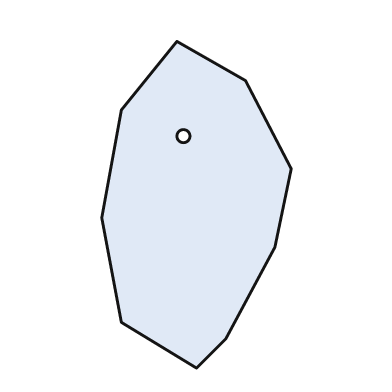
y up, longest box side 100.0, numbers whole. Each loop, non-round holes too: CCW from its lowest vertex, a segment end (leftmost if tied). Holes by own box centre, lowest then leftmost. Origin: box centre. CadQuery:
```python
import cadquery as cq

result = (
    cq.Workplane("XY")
    .moveTo(0.0, -50.0)
    .lineTo(9.0, -41.0)
    .lineTo(24.0, -13.0)
    .lineTo(29.0, 11.0)
    .lineTo(15.0, 38.0)
    .lineTo(-6.0, 50.0)
    .lineTo(-23.0, 29.0)
    .lineTo(-29.0, -4.0)
    .lineTo(-23.0, -36.0)
    .close()
    .moveTo(-4.0, 21.0)
    .circle(2.0)
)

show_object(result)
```